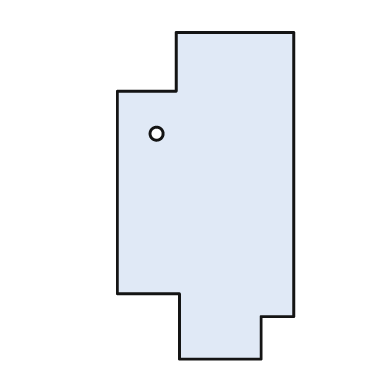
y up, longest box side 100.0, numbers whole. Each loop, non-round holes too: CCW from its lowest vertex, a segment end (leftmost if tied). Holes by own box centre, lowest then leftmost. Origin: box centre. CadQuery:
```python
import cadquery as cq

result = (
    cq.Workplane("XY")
    .moveTo(-8.0, -50.0)
    .lineTo(17.0, -50.0)
    .lineTo(17.0, -37.0)
    .lineTo(27.0, -37.0)
    .lineTo(27.0, 50.0)
    .lineTo(-9.0, 50.0)
    .lineTo(-9.0, 32.0)
    .lineTo(-27.0, 32.0)
    .lineTo(-27.0, -30.0)
    .lineTo(-8.0, -30.0)
    .close()
    .moveTo(-15.0, 19.0)
    .circle(2.0)
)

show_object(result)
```